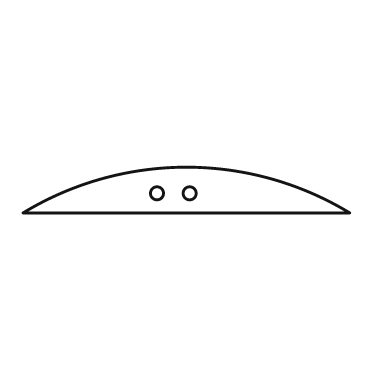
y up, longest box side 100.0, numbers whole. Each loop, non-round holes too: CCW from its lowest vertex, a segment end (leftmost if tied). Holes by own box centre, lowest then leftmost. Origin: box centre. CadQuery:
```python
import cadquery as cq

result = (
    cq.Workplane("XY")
    .moveTo(-50.0, -7.0)
    .lineTo(50.0, -7.0)
    .threePointArc((0.0, 7.0), (-50.0, -7.0))
    .close()
    .moveTo(-9.0, -1.0)
    .circle(2.0)
    .moveTo(1.0, -1.0)
    .circle(2.0)
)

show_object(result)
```